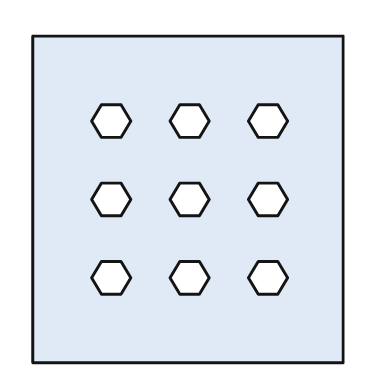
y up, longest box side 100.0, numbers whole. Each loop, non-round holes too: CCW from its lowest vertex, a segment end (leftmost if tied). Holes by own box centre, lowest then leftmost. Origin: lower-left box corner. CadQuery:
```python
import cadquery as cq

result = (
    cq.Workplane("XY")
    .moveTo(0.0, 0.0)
    .lineTo(95.0, 0.0)
    .lineTo(95.0, 100.0)
    .lineTo(0.0, 100.0)
    .close()
    .moveTo(21.0, 21.0)
    .lineTo(27.0, 21.0)
    .lineTo(30.0, 26.0)
    .lineTo(27.0, 31.0)
    .lineTo(21.0, 31.0)
    .lineTo(18.0, 26.0)
    .close()
    .moveTo(45.0, 21.0)
    .lineTo(51.0, 21.0)
    .lineTo(54.0, 26.0)
    .lineTo(51.0, 31.0)
    .lineTo(45.0, 31.0)
    .lineTo(42.0, 26.0)
    .close()
    .moveTo(69.0, 21.0)
    .lineTo(75.0, 21.0)
    .lineTo(78.0, 26.0)
    .lineTo(75.0, 31.0)
    .lineTo(69.0, 31.0)
    .lineTo(66.0, 26.0)
    .close()
    .moveTo(21.0, 45.0)
    .lineTo(27.0, 45.0)
    .lineTo(30.0, 50.0)
    .lineTo(27.0, 55.0)
    .lineTo(21.0, 55.0)
    .lineTo(18.0, 50.0)
    .close()
    .moveTo(45.0, 45.0)
    .lineTo(51.0, 45.0)
    .lineTo(54.0, 50.0)
    .lineTo(51.0, 55.0)
    .lineTo(45.0, 55.0)
    .lineTo(42.0, 50.0)
    .close()
    .moveTo(69.0, 45.0)
    .lineTo(75.0, 45.0)
    .lineTo(78.0, 50.0)
    .lineTo(75.0, 55.0)
    .lineTo(69.0, 55.0)
    .lineTo(66.0, 50.0)
    .close()
    .moveTo(21.0, 69.0)
    .lineTo(27.0, 69.0)
    .lineTo(30.0, 74.0)
    .lineTo(27.0, 79.0)
    .lineTo(21.0, 79.0)
    .lineTo(18.0, 74.0)
    .close()
    .moveTo(45.0, 69.0)
    .lineTo(51.0, 69.0)
    .lineTo(54.0, 74.0)
    .lineTo(51.0, 79.0)
    .lineTo(45.0, 79.0)
    .lineTo(42.0, 74.0)
    .close()
    .moveTo(69.0, 69.0)
    .lineTo(75.0, 69.0)
    .lineTo(78.0, 74.0)
    .lineTo(75.0, 79.0)
    .lineTo(69.0, 79.0)
    .lineTo(66.0, 74.0)
    .close()
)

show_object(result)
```